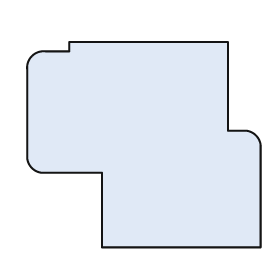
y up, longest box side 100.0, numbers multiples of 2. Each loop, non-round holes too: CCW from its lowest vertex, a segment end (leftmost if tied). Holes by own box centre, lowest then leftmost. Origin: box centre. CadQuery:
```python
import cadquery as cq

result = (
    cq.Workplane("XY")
    .moveTo(-18.0, -44.0)
    .lineTo(50.0, -44.0)
    .lineTo(50.0, 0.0)
    .threePointArc((48.0, 4.0), (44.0, 6.0))
    .lineTo(36.0, 6.0)
    .lineTo(36.0, 44.0)
    .lineTo(-32.0, 44.0)
    .lineTo(-32.0, 40.0)
    .lineTo(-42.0, 40.0)
    .threePointArc((-48.0, 38.0), (-50.0, 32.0))
    .lineTo(-50.0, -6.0)
    .threePointArc((-48.0, -10.0), (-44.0, -12.0))
    .lineTo(-18.0, -12.0)
    .close()
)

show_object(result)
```